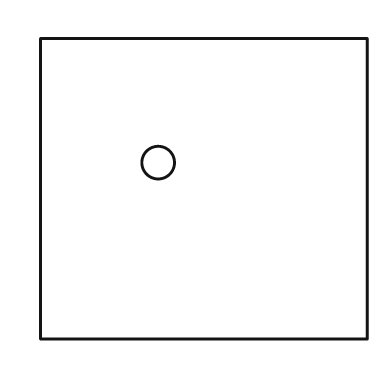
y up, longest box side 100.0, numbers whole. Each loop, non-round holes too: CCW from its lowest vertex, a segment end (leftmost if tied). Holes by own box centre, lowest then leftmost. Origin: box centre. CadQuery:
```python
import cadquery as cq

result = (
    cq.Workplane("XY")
    .moveTo(-50.0, -46.0)
    .lineTo(50.0, -46.0)
    .lineTo(50.0, 46.0)
    .lineTo(-50.0, 46.0)
    .close()
    .moveTo(-14.0, 8.0)
    .circle(5.0)
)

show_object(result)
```